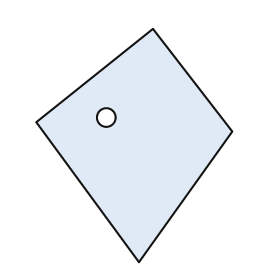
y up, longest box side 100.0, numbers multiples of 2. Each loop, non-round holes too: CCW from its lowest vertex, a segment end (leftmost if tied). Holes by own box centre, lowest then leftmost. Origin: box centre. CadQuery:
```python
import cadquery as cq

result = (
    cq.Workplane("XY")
    .moveTo(2.0, -50.0)
    .lineTo(42.0, 6.0)
    .lineTo(8.0, 50.0)
    .lineTo(-42.0, 10.0)
    .close()
    .moveTo(-12.0, 12.0)
    .circle(4.0)
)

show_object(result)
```